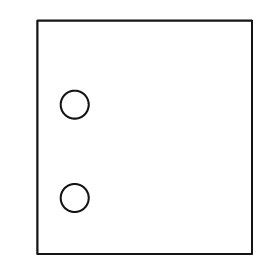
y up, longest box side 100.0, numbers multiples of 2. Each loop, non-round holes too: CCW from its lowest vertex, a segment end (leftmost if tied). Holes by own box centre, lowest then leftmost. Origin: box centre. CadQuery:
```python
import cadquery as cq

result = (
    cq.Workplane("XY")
    .moveTo(-46.0, -50.0)
    .lineTo(46.0, -50.0)
    .lineTo(46.0, 50.0)
    .lineTo(-46.0, 50.0)
    .close()
    .moveTo(-30.0, -26.0)
    .circle(6.0)
    .moveTo(-30.0, 14.0)
    .circle(6.0)
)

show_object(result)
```